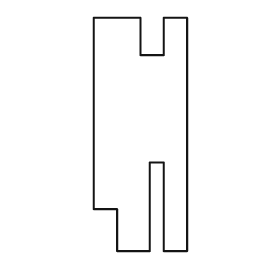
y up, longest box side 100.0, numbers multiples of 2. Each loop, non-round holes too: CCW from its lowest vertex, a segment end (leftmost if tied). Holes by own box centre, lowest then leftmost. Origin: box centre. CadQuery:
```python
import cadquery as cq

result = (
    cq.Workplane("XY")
    .moveTo(-10.0, -50.0)
    .lineTo(4.0, -50.0)
    .lineTo(4.0, -12.0)
    .lineTo(10.0, -12.0)
    .lineTo(10.0, -50.0)
    .lineTo(20.0, -50.0)
    .lineTo(20.0, 50.0)
    .lineTo(10.0, 50.0)
    .lineTo(10.0, 34.0)
    .lineTo(0.0, 34.0)
    .lineTo(0.0, 50.0)
    .lineTo(-20.0, 50.0)
    .lineTo(-20.0, -32.0)
    .lineTo(-10.0, -32.0)
    .close()
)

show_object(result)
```